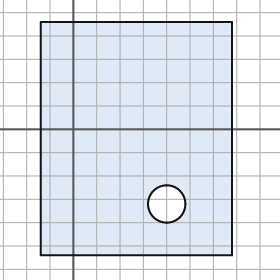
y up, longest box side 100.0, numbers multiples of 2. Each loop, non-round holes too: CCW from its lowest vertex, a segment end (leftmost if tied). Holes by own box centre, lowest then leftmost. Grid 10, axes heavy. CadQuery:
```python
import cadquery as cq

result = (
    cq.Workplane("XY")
    .moveTo(-14.0, -54.0)
    .lineTo(68.0, -54.0)
    .lineTo(68.0, 46.0)
    .lineTo(-14.0, 46.0)
    .close()
    .moveTo(40.0, -32.0)
    .circle(8.0)
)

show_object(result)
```